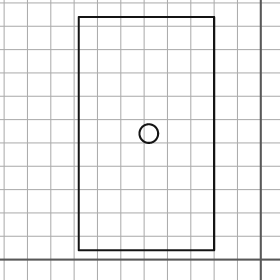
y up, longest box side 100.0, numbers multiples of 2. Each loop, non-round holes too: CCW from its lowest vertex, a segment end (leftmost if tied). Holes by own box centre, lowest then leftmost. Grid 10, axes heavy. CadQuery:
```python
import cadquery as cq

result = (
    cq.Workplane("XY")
    .moveTo(-78.0, 4.0)
    .lineTo(-20.0, 4.0)
    .lineTo(-20.0, 104.0)
    .lineTo(-78.0, 104.0)
    .close()
    .moveTo(-48.0, 54.0)
    .circle(4.0)
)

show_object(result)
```